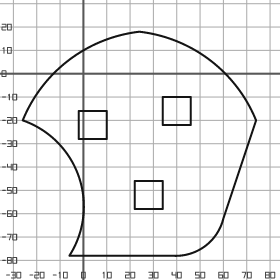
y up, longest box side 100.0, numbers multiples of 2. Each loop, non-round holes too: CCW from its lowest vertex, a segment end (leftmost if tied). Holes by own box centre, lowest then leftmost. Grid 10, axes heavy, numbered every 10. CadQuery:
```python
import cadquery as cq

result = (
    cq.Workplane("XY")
    .moveTo(-6.0, -78.0)
    .lineTo(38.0, -78.0)
    .threePointArc((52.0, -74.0), (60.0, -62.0))
    .lineTo(74.0, -20.0)
    .threePointArc((54.0, 6.0), (24.0, 18.0))
    .threePointArc((-6.0, 6.0), (-26.0, -20.0))
    .threePointArc((-2.0, -44.0), (-6.0, -78.0))
    .close()
    .moveTo(22.0, -58.0)
    .lineTo(34.0, -58.0)
    .lineTo(34.0, -46.0)
    .lineTo(22.0, -46.0)
    .close()
    .moveTo(-2.0, -28.0)
    .lineTo(10.0, -28.0)
    .lineTo(10.0, -16.0)
    .lineTo(-2.0, -16.0)
    .close()
    .moveTo(34.0, -22.0)
    .lineTo(46.0, -22.0)
    .lineTo(46.0, -10.0)
    .lineTo(34.0, -10.0)
    .close()
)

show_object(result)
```